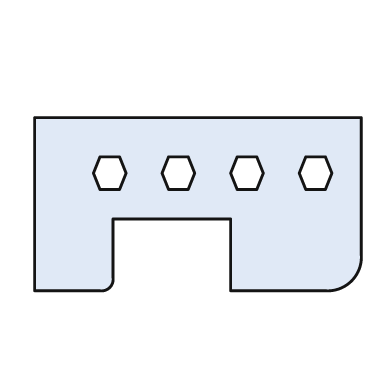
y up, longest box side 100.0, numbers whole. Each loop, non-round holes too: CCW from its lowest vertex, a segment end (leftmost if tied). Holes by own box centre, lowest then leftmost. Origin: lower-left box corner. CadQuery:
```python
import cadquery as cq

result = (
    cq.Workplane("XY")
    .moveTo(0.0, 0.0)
    .lineTo(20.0, 0.0)
    .threePointArc((23.0, 1.0), (24.0, 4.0))
    .lineTo(24.0, 22.0)
    .lineTo(60.0, 22.0)
    .lineTo(60.0, 0.0)
    .lineTo(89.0, 0.0)
    .threePointArc((97.0, 3.0), (100.0, 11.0))
    .lineTo(100.0, 53.0)
    .lineTo(0.0, 53.0)
    .close()
    .moveTo(20.0, 31.0)
    .lineTo(26.0, 31.0)
    .lineTo(28.0, 36.0)
    .lineTo(26.0, 41.0)
    .lineTo(20.0, 41.0)
    .lineTo(18.0, 36.0)
    .close()
    .moveTo(41.0, 31.0)
    .lineTo(47.0, 31.0)
    .lineTo(49.0, 36.0)
    .lineTo(47.0, 41.0)
    .lineTo(41.0, 41.0)
    .lineTo(39.0, 36.0)
    .close()
    .moveTo(62.0, 31.0)
    .lineTo(68.0, 31.0)
    .lineTo(70.0, 36.0)
    .lineTo(68.0, 41.0)
    .lineTo(62.0, 41.0)
    .lineTo(60.0, 36.0)
    .close()
    .moveTo(83.0, 31.0)
    .lineTo(89.0, 31.0)
    .lineTo(91.0, 36.0)
    .lineTo(89.0, 41.0)
    .lineTo(83.0, 41.0)
    .lineTo(81.0, 36.0)
    .close()
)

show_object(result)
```